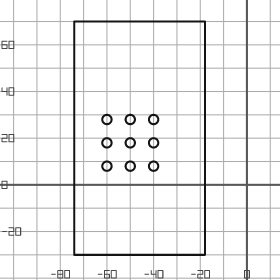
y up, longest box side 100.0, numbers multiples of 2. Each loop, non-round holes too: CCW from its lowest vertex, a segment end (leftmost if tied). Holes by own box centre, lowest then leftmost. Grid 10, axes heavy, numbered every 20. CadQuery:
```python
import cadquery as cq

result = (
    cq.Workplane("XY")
    .moveTo(-74.0, -30.0)
    .lineTo(-18.0, -30.0)
    .lineTo(-18.0, 70.0)
    .lineTo(-74.0, 70.0)
    .close()
    .moveTo(-60.0, 8.0)
    .circle(2.0)
    .moveTo(-50.0, 8.0)
    .circle(2.0)
    .moveTo(-40.0, 8.0)
    .circle(2.0)
    .moveTo(-60.0, 18.0)
    .circle(2.0)
    .moveTo(-50.0, 18.0)
    .circle(2.0)
    .moveTo(-40.0, 18.0)
    .circle(2.0)
    .moveTo(-60.0, 28.0)
    .circle(2.0)
    .moveTo(-50.0, 28.0)
    .circle(2.0)
    .moveTo(-40.0, 28.0)
    .circle(2.0)
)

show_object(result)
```